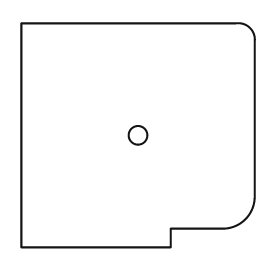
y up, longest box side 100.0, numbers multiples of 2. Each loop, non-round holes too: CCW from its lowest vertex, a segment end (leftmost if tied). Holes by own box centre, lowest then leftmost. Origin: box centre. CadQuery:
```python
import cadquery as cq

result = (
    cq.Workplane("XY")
    .moveTo(-50.0, -48.0)
    .lineTo(14.0, -48.0)
    .lineTo(14.0, -40.0)
    .lineTo(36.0, -40.0)
    .threePointArc((46.0, -36.0), (50.0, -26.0))
    .lineTo(50.0, 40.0)
    .threePointArc((48.0, 46.0), (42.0, 48.0))
    .lineTo(-50.0, 48.0)
    .close()
    .moveTo(0.0, 0.0)
    .circle(4.0)
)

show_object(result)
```